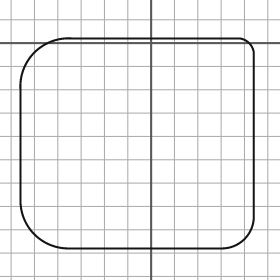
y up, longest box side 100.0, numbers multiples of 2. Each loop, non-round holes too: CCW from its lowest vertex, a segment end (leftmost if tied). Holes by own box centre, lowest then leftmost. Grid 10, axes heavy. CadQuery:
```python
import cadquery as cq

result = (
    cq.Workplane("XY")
    .moveTo(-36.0, -88.0)
    .lineTo(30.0, -88.0)
    .threePointArc((40.0, -84.0), (44.0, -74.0))
    .lineTo(44.0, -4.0)
    .threePointArc((42.0, 0.0), (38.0, 2.0))
    .lineTo(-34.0, 2.0)
    .threePointArc((-50.0, -4.0), (-56.0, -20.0))
    .lineTo(-56.0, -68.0)
    .threePointArc((-50.0, -82.0), (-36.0, -88.0))
    .close()
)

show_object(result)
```